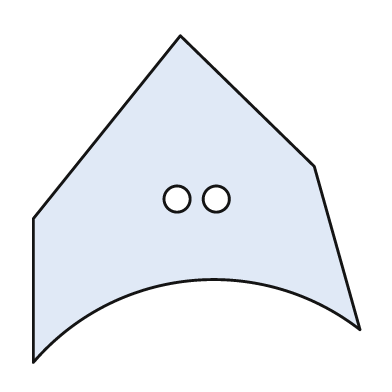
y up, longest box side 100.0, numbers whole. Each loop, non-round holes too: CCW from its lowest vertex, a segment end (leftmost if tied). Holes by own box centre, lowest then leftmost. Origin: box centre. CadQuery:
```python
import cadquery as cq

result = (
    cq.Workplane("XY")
    .moveTo(-50.0, -50.0)
    .threePointArc((-2.0, -25.0), (50.0, -40.0))
    .lineTo(36.0, 10.0)
    .lineTo(-5.0, 50.0)
    .lineTo(-50.0, -6.0)
    .close()
    .moveTo(-6.0, 0.0)
    .circle(4.0)
    .moveTo(6.0, 0.0)
    .circle(4.0)
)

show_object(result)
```